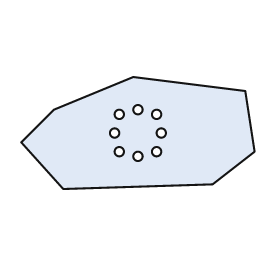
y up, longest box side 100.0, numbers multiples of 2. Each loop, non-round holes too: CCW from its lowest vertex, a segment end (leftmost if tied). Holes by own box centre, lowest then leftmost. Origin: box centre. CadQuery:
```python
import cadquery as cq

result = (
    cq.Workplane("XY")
    .moveTo(-32.0, -24.0)
    .lineTo(32.0, -22.0)
    .lineTo(50.0, -8.0)
    .lineTo(46.0, 18.0)
    .lineTo(-2.0, 24.0)
    .lineTo(-36.0, 10.0)
    .lineTo(-50.0, -4.0)
    .close()
    .moveTo(0.0, -10.0)
    .circle(2.0)
    .moveTo(-8.0, -8.0)
    .circle(2.0)
    .moveTo(8.0, -8.0)
    .circle(2.0)
    .moveTo(-10.0, 0.0)
    .circle(2.0)
    .moveTo(10.0, 0.0)
    .circle(2.0)
    .moveTo(-8.0, 8.0)
    .circle(2.0)
    .moveTo(8.0, 8.0)
    .circle(2.0)
    .moveTo(0.0, 10.0)
    .circle(2.0)
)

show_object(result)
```